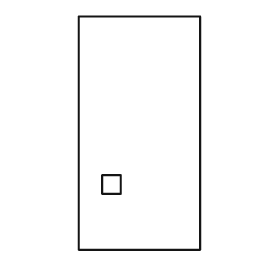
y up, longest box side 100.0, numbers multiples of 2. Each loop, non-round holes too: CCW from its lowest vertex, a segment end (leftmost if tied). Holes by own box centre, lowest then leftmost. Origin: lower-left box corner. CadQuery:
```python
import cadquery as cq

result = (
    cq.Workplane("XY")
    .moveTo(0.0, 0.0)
    .lineTo(52.0, 0.0)
    .lineTo(52.0, 100.0)
    .lineTo(0.0, 100.0)
    .close()
    .moveTo(10.0, 24.0)
    .lineTo(18.0, 24.0)
    .lineTo(18.0, 32.0)
    .lineTo(10.0, 32.0)
    .close()
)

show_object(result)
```